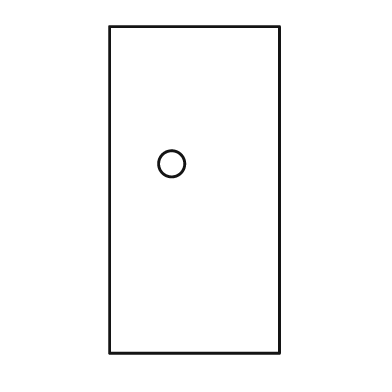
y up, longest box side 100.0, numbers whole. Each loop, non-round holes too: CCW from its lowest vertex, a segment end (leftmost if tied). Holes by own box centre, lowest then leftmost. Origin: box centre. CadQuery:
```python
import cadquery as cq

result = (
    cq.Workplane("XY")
    .moveTo(-26.0, -50.0)
    .lineTo(26.0, -50.0)
    .lineTo(26.0, 50.0)
    .lineTo(-26.0, 50.0)
    .close()
    .moveTo(-7.0, 8.0)
    .circle(4.0)
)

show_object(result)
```